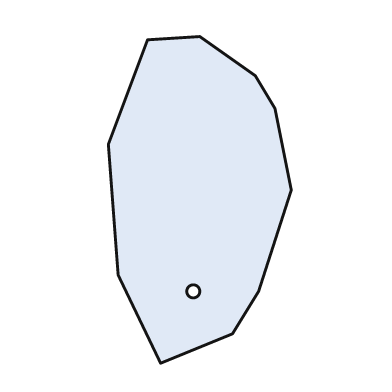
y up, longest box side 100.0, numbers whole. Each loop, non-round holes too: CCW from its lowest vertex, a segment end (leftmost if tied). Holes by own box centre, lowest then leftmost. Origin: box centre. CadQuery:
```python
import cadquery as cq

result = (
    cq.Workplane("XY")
    .moveTo(-12.0, -50.0)
    .lineTo(10.0, -41.0)
    .lineTo(18.0, -28.0)
    .lineTo(28.0, 3.0)
    .lineTo(23.0, 28.0)
    .lineTo(17.0, 38.0)
    .lineTo(0.0, 50.0)
    .lineTo(-16.0, 49.0)
    .lineTo(-28.0, 17.0)
    .lineTo(-25.0, -23.0)
    .close()
    .moveTo(-2.0, -28.0)
    .circle(2.0)
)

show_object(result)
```